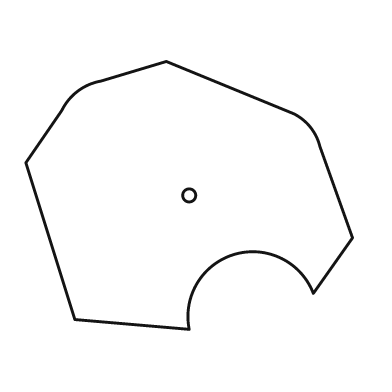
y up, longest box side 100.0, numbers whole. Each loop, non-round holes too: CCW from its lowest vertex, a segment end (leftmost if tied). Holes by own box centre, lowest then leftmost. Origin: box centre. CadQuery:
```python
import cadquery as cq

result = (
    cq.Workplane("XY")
    .moveTo(0.0, -41.0)
    .threePointArc((14.0, -18.0), (38.0, -30.0))
    .lineTo(50.0, -13.0)
    .lineTo(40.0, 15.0)
    .threePointArc((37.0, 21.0), (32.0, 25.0))
    .lineTo(-7.0, 41.0)
    .lineTo(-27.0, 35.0)
    .threePointArc((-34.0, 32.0), (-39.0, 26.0))
    .lineTo(-50.0, 10.0)
    .lineTo(-35.0, -38.0)
    .close()
    .moveTo(0.0, 0.0)
    .circle(2.0)
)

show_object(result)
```